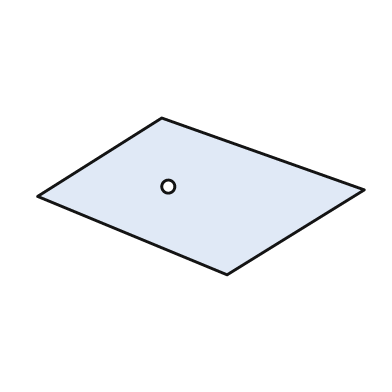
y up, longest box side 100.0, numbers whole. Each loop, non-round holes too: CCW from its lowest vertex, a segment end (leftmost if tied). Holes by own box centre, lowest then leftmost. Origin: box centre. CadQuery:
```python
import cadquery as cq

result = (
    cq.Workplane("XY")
    .moveTo(8.0, -24.0)
    .lineTo(50.0, 2.0)
    .lineTo(-12.0, 24.0)
    .lineTo(-50.0, 0.0)
    .close()
    .moveTo(-10.0, 3.0)
    .circle(2.0)
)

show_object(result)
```